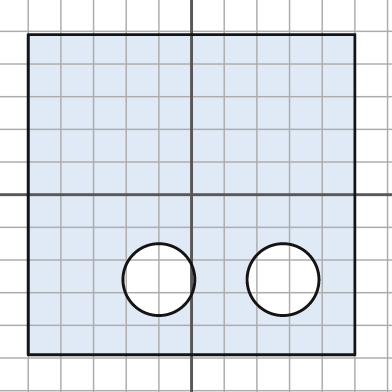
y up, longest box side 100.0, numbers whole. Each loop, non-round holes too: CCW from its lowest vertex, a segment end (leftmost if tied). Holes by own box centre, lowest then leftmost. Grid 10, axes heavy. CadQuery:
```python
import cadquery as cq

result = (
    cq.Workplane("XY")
    .moveTo(-50.0, -49.0)
    .lineTo(50.0, -49.0)
    .lineTo(50.0, 49.0)
    .lineTo(-50.0, 49.0)
    .close()
    .moveTo(-10.0, -26.0)
    .circle(11.0)
    .moveTo(28.0, -26.0)
    .circle(11.0)
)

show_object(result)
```